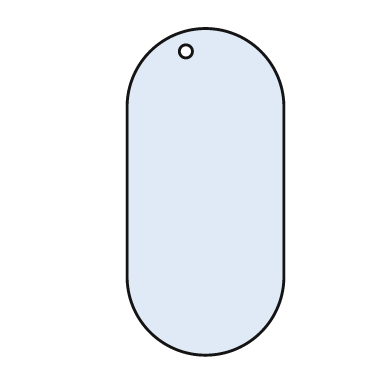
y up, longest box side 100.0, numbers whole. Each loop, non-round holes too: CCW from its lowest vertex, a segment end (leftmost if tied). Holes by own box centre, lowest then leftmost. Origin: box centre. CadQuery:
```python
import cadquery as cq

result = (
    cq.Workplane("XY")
    .moveTo(-24.0, -26.0)
    .threePointArc((0.0, -50.0), (24.0, -26.0))
    .lineTo(24.0, 26.0)
    .threePointArc((0.0, 50.0), (-24.0, 26.0))
    .close()
    .moveTo(-6.0, 43.0)
    .circle(2.0)
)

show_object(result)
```